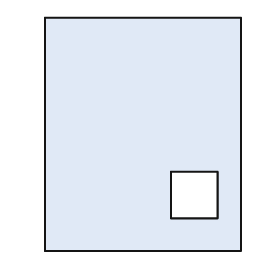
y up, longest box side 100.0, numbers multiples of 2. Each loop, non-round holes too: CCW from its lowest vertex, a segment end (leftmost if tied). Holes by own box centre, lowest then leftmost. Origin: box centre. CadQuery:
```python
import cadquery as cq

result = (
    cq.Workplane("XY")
    .moveTo(-42.0, -50.0)
    .lineTo(42.0, -50.0)
    .lineTo(42.0, 50.0)
    .lineTo(-42.0, 50.0)
    .close()
    .moveTo(12.0, -36.0)
    .lineTo(32.0, -36.0)
    .lineTo(32.0, -16.0)
    .lineTo(12.0, -16.0)
    .close()
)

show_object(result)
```